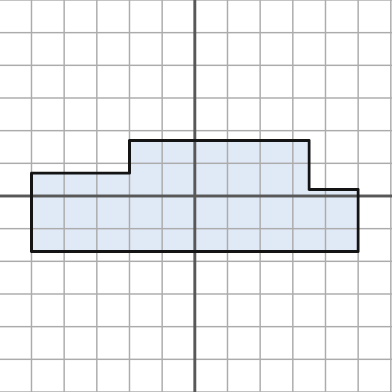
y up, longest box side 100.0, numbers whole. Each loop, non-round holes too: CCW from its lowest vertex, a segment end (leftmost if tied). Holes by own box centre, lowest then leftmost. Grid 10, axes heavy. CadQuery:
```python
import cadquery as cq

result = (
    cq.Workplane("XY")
    .moveTo(-50.0, -17.0)
    .lineTo(50.0, -17.0)
    .lineTo(50.0, 2.0)
    .lineTo(35.0, 2.0)
    .lineTo(35.0, 17.0)
    .lineTo(-20.0, 17.0)
    .lineTo(-20.0, 7.0)
    .lineTo(-50.0, 7.0)
    .close()
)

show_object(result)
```